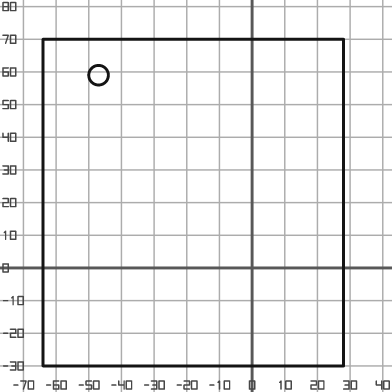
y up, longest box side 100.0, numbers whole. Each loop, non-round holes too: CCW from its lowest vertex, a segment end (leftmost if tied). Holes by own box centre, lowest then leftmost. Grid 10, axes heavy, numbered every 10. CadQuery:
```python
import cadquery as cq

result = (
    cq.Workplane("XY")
    .moveTo(-64.0, -30.0)
    .lineTo(28.0, -30.0)
    .lineTo(28.0, 70.0)
    .lineTo(-64.0, 70.0)
    .close()
    .moveTo(-47.0, 59.0)
    .circle(3.0)
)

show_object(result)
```